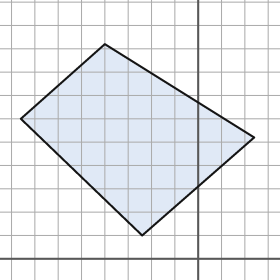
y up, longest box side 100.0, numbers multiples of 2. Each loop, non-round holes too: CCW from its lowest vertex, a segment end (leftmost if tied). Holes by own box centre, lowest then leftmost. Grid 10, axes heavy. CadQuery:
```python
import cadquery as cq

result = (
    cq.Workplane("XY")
    .moveTo(-24.0, 10.0)
    .lineTo(24.0, 52.0)
    .lineTo(-40.0, 92.0)
    .lineTo(-76.0, 60.0)
    .close()
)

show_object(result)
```